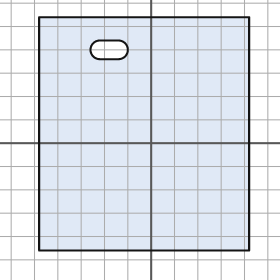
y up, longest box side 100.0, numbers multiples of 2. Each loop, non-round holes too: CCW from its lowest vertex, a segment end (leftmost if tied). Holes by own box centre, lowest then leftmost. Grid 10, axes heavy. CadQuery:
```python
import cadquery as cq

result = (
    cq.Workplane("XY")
    .moveTo(-48.0, -46.0)
    .lineTo(42.0, -46.0)
    .lineTo(42.0, 54.0)
    .lineTo(-48.0, 54.0)
    .close()
    .moveTo(-22.0, 36.0)
    .lineTo(-14.0, 36.0)
    .threePointArc((-10.0, 40.0), (-14.0, 44.0))
    .lineTo(-22.0, 44.0)
    .threePointArc((-26.0, 40.0), (-22.0, 36.0))
    .close()
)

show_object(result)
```